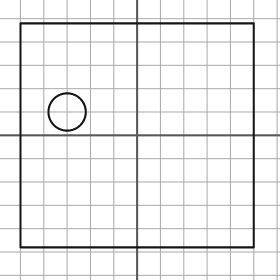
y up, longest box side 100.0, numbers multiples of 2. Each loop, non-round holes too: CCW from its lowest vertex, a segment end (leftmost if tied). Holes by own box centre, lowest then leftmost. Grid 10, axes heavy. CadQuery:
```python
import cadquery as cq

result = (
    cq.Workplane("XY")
    .moveTo(-50.0, -48.0)
    .lineTo(50.0, -48.0)
    .lineTo(50.0, 48.0)
    .lineTo(-50.0, 48.0)
    .close()
    .moveTo(-30.0, 10.0)
    .circle(8.0)
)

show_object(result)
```